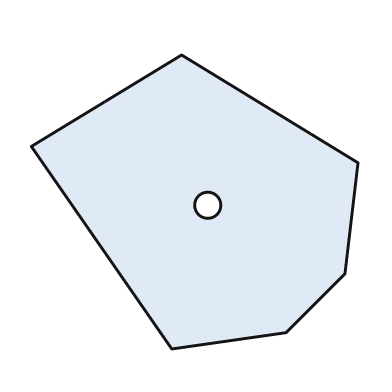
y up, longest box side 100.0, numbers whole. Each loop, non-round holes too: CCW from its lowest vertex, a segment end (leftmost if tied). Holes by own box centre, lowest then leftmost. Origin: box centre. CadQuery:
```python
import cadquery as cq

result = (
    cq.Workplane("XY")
    .moveTo(-7.0, -45.0)
    .lineTo(28.0, -40.0)
    .lineTo(46.0, -22.0)
    .lineTo(50.0, 12.0)
    .lineTo(-4.0, 45.0)
    .lineTo(-50.0, 17.0)
    .close()
    .moveTo(4.0, -1.0)
    .circle(4.0)
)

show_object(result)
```